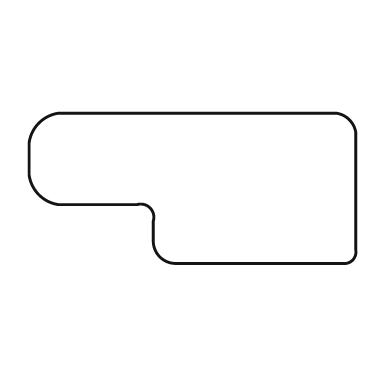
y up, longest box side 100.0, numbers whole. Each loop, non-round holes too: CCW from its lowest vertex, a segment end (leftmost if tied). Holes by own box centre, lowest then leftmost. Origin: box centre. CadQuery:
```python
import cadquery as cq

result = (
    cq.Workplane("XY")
    .moveTo(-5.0, -23.0)
    .lineTo(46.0, -23.0)
    .threePointArc((49.0, -22.0), (50.0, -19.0))
    .lineTo(50.0, 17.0)
    .threePointArc((48.0, 21.0), (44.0, 23.0))
    .lineTo(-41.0, 23.0)
    .threePointArc((-47.0, 20.0), (-50.0, 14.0))
    .lineTo(-50.0, 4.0)
    .threePointArc((-47.0, -2.0), (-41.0, -5.0))
    .lineTo(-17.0, -5.0)
    .threePointArc((-13.0, -6.0), (-12.0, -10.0))
    .lineTo(-12.0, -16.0)
    .threePointArc((-10.0, -21.0), (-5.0, -23.0))
    .close()
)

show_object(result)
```